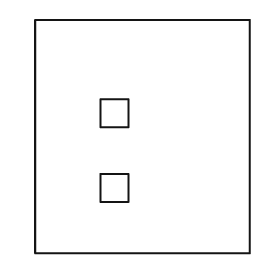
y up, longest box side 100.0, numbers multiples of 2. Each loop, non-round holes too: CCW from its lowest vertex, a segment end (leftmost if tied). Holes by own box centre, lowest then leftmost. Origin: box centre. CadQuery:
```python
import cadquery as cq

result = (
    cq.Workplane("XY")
    .moveTo(-46.0, -50.0)
    .lineTo(46.0, -50.0)
    .lineTo(46.0, 50.0)
    .lineTo(-46.0, 50.0)
    .close()
    .moveTo(-18.0, -28.0)
    .lineTo(-6.0, -28.0)
    .lineTo(-6.0, -16.0)
    .lineTo(-18.0, -16.0)
    .close()
    .moveTo(-18.0, 4.0)
    .lineTo(-6.0, 4.0)
    .lineTo(-6.0, 16.0)
    .lineTo(-18.0, 16.0)
    .close()
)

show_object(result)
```